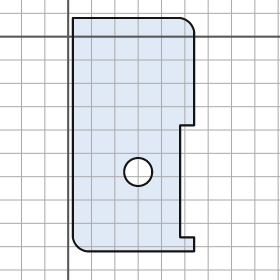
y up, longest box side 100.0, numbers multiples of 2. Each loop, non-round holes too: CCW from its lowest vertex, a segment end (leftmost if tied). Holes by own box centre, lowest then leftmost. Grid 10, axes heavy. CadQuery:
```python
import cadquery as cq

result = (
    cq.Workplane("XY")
    .moveTo(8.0, -92.0)
    .lineTo(54.0, -92.0)
    .lineTo(54.0, -86.0)
    .lineTo(48.0, -86.0)
    .lineTo(48.0, -38.0)
    .lineTo(54.0, -38.0)
    .lineTo(54.0, 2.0)
    .threePointArc((52.0, 6.0), (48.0, 8.0))
    .lineTo(2.0, 8.0)
    .lineTo(2.0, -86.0)
    .threePointArc((4.0, -90.0), (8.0, -92.0))
    .close()
    .moveTo(30.0, -58.0)
    .circle(6.0)
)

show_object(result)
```